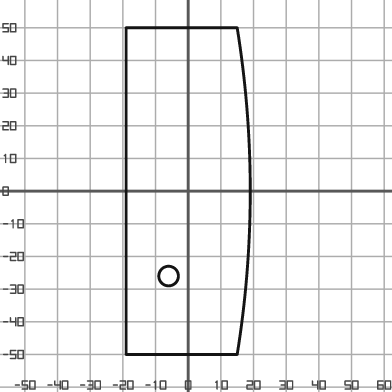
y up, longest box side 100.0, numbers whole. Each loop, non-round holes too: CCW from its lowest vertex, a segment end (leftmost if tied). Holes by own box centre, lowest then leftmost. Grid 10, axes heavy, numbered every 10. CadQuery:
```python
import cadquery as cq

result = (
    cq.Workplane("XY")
    .moveTo(-19.0, -50.0)
    .lineTo(15.0, -50.0)
    .threePointArc((19.0, 0.0), (15.0, 50.0))
    .lineTo(-19.0, 50.0)
    .close()
    .moveTo(-6.0, -26.0)
    .circle(3.0)
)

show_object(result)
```